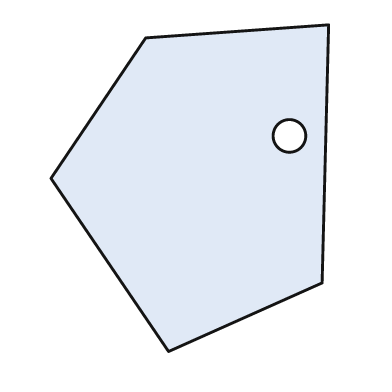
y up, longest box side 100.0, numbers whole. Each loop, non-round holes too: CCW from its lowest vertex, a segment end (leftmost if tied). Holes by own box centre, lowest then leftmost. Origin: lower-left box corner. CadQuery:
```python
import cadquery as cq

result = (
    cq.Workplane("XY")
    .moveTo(36.0, 0.0)
    .lineTo(83.0, 21.0)
    .lineTo(85.0, 100.0)
    .lineTo(29.0, 96.0)
    .lineTo(0.0, 53.0)
    .close()
    .moveTo(73.0, 66.0)
    .circle(5.0)
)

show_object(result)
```